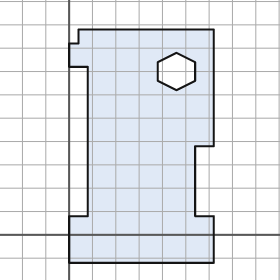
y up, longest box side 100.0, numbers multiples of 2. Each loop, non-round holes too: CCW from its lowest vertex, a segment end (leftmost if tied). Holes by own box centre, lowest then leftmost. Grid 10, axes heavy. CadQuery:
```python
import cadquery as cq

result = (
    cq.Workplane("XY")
    .moveTo(0.0, -12.0)
    .lineTo(62.0, -12.0)
    .lineTo(62.0, 8.0)
    .lineTo(54.0, 8.0)
    .lineTo(54.0, 38.0)
    .lineTo(62.0, 38.0)
    .lineTo(62.0, 88.0)
    .lineTo(4.0, 88.0)
    .lineTo(4.0, 82.0)
    .lineTo(0.0, 82.0)
    .lineTo(0.0, 72.0)
    .lineTo(8.0, 72.0)
    .lineTo(8.0, 8.0)
    .lineTo(0.0, 8.0)
    .close()
    .moveTo(46.0, 62.0)
    .lineTo(54.0, 66.0)
    .lineTo(54.0, 74.0)
    .lineTo(46.0, 78.0)
    .lineTo(38.0, 74.0)
    .lineTo(38.0, 66.0)
    .close()
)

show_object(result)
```